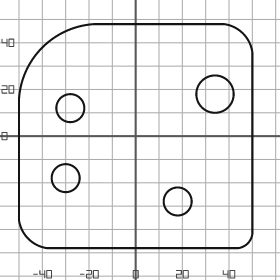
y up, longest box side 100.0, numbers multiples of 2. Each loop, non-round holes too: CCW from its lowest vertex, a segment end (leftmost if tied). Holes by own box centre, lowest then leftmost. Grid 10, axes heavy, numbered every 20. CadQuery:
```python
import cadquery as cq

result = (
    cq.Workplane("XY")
    .moveTo(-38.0, -48.0)
    .lineTo(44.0, -48.0)
    .threePointArc((48.0, -46.0), (50.0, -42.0))
    .lineTo(50.0, 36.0)
    .threePointArc((46.0, 44.0), (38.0, 48.0))
    .lineTo(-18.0, 48.0)
    .threePointArc((-40.0, 38.0), (-50.0, 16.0))
    .lineTo(-50.0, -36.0)
    .threePointArc((-46.0, -44.0), (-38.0, -48.0))
    .close()
    .moveTo(18.0, -28.0)
    .circle(6.0)
    .moveTo(-30.0, -18.0)
    .circle(6.0)
    .moveTo(-28.0, 12.0)
    .circle(6.0)
    .moveTo(34.0, 18.0)
    .circle(8.0)
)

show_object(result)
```